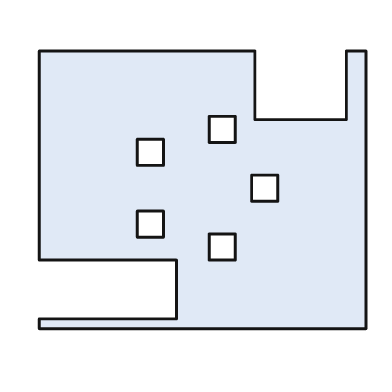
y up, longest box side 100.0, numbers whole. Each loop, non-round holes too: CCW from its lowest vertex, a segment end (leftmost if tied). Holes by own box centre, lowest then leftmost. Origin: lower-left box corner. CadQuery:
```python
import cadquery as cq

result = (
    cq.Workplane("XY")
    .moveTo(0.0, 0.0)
    .lineTo(100.0, 0.0)
    .lineTo(100.0, 85.0)
    .lineTo(94.0, 85.0)
    .lineTo(94.0, 64.0)
    .lineTo(66.0, 64.0)
    .lineTo(66.0, 85.0)
    .lineTo(0.0, 85.0)
    .lineTo(0.0, 21.0)
    .lineTo(42.0, 21.0)
    .lineTo(42.0, 3.0)
    .lineTo(0.0, 3.0)
    .close()
    .moveTo(52.0, 21.0)
    .lineTo(60.0, 21.0)
    .lineTo(60.0, 29.0)
    .lineTo(52.0, 29.0)
    .close()
    .moveTo(30.0, 28.0)
    .lineTo(38.0, 28.0)
    .lineTo(38.0, 36.0)
    .lineTo(30.0, 36.0)
    .close()
    .moveTo(65.0, 39.0)
    .lineTo(73.0, 39.0)
    .lineTo(73.0, 47.0)
    .lineTo(65.0, 47.0)
    .close()
    .moveTo(30.0, 50.0)
    .lineTo(38.0, 50.0)
    .lineTo(38.0, 58.0)
    .lineTo(30.0, 58.0)
    .close()
    .moveTo(52.0, 57.0)
    .lineTo(60.0, 57.0)
    .lineTo(60.0, 65.0)
    .lineTo(52.0, 65.0)
    .close()
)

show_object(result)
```